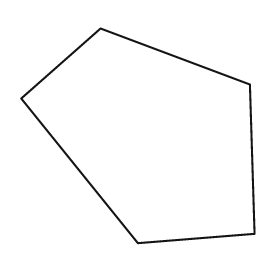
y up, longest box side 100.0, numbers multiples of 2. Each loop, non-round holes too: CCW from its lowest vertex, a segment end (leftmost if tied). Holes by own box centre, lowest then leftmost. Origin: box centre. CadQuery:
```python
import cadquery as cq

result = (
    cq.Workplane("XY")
    .moveTo(0.0, -46.0)
    .lineTo(50.0, -42.0)
    .lineTo(48.0, 22.0)
    .lineTo(-16.0, 46.0)
    .lineTo(-50.0, 16.0)
    .close()
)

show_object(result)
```